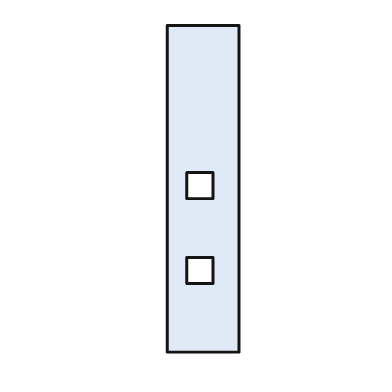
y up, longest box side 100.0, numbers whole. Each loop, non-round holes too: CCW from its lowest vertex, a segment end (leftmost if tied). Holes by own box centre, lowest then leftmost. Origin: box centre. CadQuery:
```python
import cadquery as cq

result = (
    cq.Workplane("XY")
    .moveTo(-11.0, -50.0)
    .lineTo(11.0, -50.0)
    .lineTo(11.0, 50.0)
    .lineTo(-11.0, 50.0)
    .close()
    .moveTo(-5.0, -29.0)
    .lineTo(3.0, -29.0)
    .lineTo(3.0, -21.0)
    .lineTo(-5.0, -21.0)
    .close()
    .moveTo(-5.0, -3.0)
    .lineTo(3.0, -3.0)
    .lineTo(3.0, 5.0)
    .lineTo(-5.0, 5.0)
    .close()
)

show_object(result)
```